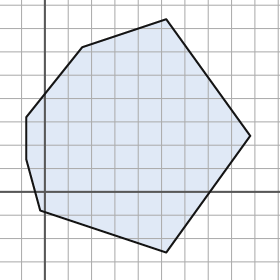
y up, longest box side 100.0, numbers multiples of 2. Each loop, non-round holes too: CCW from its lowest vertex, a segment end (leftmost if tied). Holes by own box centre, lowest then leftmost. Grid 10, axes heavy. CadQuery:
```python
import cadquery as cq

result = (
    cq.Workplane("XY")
    .moveTo(52.0, -26.0)
    .lineTo(88.0, 24.0)
    .lineTo(52.0, 74.0)
    .lineTo(16.0, 62.0)
    .lineTo(-8.0, 32.0)
    .lineTo(-8.0, 14.0)
    .lineTo(-2.0, -8.0)
    .close()
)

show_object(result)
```